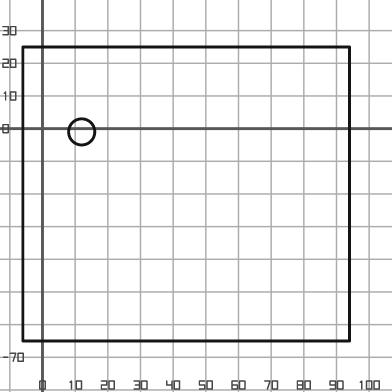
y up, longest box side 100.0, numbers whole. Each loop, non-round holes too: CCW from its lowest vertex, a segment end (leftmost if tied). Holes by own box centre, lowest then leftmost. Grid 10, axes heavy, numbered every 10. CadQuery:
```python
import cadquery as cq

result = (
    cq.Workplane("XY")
    .moveTo(-6.0, -65.0)
    .lineTo(94.0, -65.0)
    .lineTo(94.0, 25.0)
    .lineTo(-6.0, 25.0)
    .close()
    .moveTo(12.0, -1.0)
    .circle(4.0)
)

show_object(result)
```